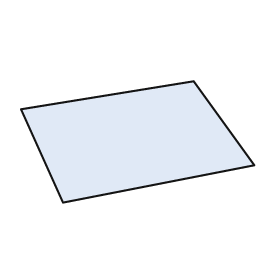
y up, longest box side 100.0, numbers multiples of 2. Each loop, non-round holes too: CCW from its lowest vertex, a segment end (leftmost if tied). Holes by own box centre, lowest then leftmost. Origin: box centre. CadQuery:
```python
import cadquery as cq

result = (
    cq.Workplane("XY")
    .moveTo(-32.0, -26.0)
    .lineTo(50.0, -10.0)
    .lineTo(24.0, 26.0)
    .lineTo(-50.0, 14.0)
    .close()
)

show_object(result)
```